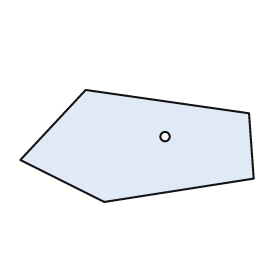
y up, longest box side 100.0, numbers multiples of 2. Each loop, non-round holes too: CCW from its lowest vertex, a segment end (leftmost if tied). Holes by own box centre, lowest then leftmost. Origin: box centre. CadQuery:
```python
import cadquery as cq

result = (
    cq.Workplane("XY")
    .moveTo(-14.0, -24.0)
    .lineTo(50.0, -14.0)
    .lineTo(48.0, 14.0)
    .lineTo(-22.0, 24.0)
    .lineTo(-50.0, -6.0)
    .close()
    .moveTo(12.0, 4.0)
    .circle(2.0)
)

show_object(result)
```